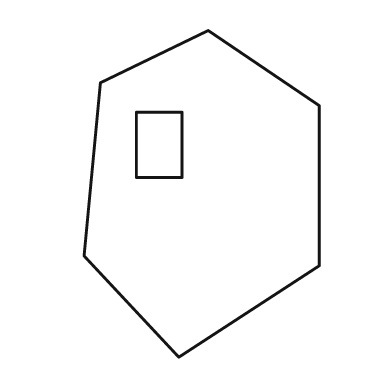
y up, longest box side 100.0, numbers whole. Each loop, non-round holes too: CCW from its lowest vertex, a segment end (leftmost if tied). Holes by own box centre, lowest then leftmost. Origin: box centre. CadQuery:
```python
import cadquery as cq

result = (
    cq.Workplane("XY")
    .moveTo(-7.0, -50.0)
    .lineTo(36.0, -22.0)
    .lineTo(36.0, 27.0)
    .lineTo(2.0, 50.0)
    .lineTo(-31.0, 34.0)
    .lineTo(-36.0, -19.0)
    .close()
    .moveTo(-20.0, 5.0)
    .lineTo(-6.0, 5.0)
    .lineTo(-6.0, 25.0)
    .lineTo(-20.0, 25.0)
    .close()
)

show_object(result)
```